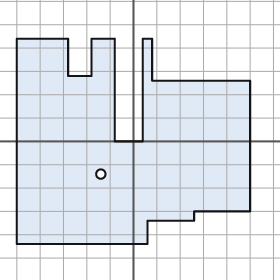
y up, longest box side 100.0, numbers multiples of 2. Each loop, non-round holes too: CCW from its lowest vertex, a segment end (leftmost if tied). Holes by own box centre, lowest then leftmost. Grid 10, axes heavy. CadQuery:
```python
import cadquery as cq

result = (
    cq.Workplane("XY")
    .moveTo(-50.0, -44.0)
    .lineTo(6.0, -44.0)
    .lineTo(6.0, -34.0)
    .lineTo(26.0, -34.0)
    .lineTo(26.0, -30.0)
    .lineTo(50.0, -30.0)
    .lineTo(50.0, 26.0)
    .lineTo(8.0, 26.0)
    .lineTo(8.0, 44.0)
    .lineTo(4.0, 44.0)
    .lineTo(4.0, 0.0)
    .lineTo(-8.0, 0.0)
    .lineTo(-8.0, 44.0)
    .lineTo(-18.0, 44.0)
    .lineTo(-18.0, 28.0)
    .lineTo(-28.0, 28.0)
    .lineTo(-28.0, 44.0)
    .lineTo(-50.0, 44.0)
    .close()
    .moveTo(-14.0, -14.0)
    .circle(2.0)
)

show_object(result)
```